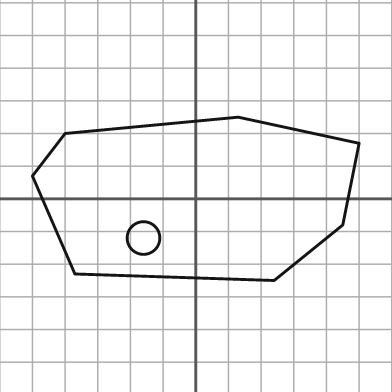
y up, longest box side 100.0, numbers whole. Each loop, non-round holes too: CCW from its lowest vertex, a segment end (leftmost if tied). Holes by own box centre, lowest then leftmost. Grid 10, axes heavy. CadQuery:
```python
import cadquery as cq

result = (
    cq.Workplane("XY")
    .moveTo(24.0, -25.0)
    .lineTo(45.0, -8.0)
    .lineTo(50.0, 17.0)
    .lineTo(13.0, 25.0)
    .lineTo(-40.0, 20.0)
    .lineTo(-50.0, 7.0)
    .lineTo(-37.0, -23.0)
    .close()
    .moveTo(-16.0, -12.0)
    .circle(5.0)
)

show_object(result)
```